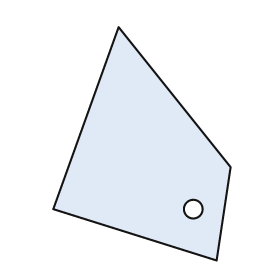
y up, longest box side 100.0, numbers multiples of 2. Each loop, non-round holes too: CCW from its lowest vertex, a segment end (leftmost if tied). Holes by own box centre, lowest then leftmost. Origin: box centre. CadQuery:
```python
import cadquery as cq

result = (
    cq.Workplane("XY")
    .moveTo(32.0, -50.0)
    .lineTo(38.0, -10.0)
    .lineTo(-10.0, 50.0)
    .lineTo(-38.0, -28.0)
    .close()
    .moveTo(22.0, -28.0)
    .circle(4.0)
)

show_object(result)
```